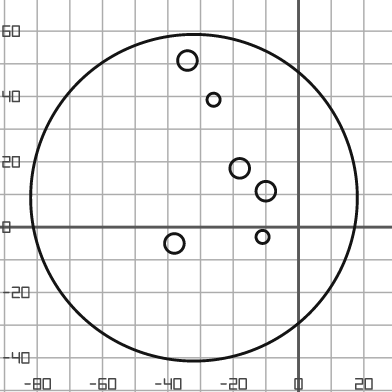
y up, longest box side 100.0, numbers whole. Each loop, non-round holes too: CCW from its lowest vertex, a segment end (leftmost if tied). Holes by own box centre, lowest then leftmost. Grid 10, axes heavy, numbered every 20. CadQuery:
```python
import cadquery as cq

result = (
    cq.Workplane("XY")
    .moveTo(-32.0, 9.0)
    .circle(50.0)
    .moveTo(-38.0, -5.0)
    .circle(3.0)
    .moveTo(-11.0, -3.0)
    .circle(2.0)
    .moveTo(-10.0, 11.0)
    .circle(3.0)
    .moveTo(-18.0, 18.0)
    .circle(3.0)
    .moveTo(-26.0, 39.0)
    .circle(2.0)
    .moveTo(-34.0, 51.0)
    .circle(3.0)
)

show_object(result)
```